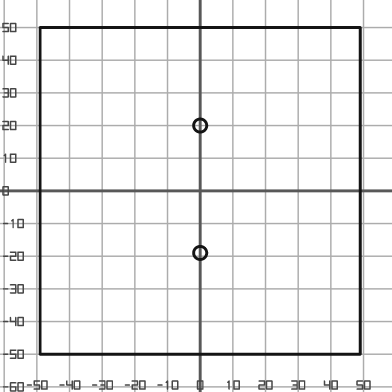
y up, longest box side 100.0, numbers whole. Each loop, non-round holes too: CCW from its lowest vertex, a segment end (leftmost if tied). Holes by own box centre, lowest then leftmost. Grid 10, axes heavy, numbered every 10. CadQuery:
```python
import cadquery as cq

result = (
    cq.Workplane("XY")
    .moveTo(-49.0, -50.0)
    .lineTo(49.0, -50.0)
    .lineTo(49.0, 50.0)
    .lineTo(-49.0, 50.0)
    .close()
    .moveTo(0.0, -19.0)
    .circle(2.0)
    .moveTo(0.0, 20.0)
    .circle(2.0)
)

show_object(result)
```